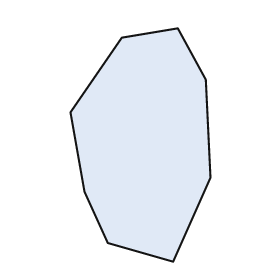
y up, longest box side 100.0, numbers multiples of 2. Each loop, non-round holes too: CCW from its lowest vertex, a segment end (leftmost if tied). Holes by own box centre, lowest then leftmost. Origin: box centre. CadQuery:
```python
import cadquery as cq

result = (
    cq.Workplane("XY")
    .moveTo(14.0, -50.0)
    .lineTo(30.0, -14.0)
    .lineTo(28.0, 28.0)
    .lineTo(16.0, 50.0)
    .lineTo(-8.0, 46.0)
    .lineTo(-30.0, 14.0)
    .lineTo(-24.0, -20.0)
    .lineTo(-14.0, -42.0)
    .close()
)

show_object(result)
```